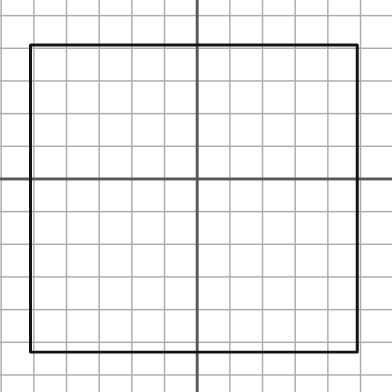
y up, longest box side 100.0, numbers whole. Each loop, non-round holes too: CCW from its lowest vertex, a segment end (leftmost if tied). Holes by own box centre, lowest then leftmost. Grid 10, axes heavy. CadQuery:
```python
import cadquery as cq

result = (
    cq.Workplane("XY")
    .moveTo(-51.0, -53.0)
    .lineTo(49.0, -53.0)
    .lineTo(49.0, 41.0)
    .lineTo(-51.0, 41.0)
    .close()
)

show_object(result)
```